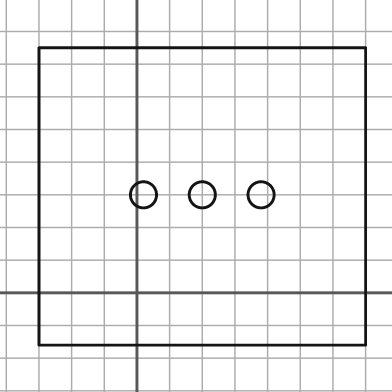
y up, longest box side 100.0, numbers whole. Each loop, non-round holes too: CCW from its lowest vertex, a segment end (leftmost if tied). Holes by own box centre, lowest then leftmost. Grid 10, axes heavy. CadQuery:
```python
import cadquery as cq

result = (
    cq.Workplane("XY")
    .moveTo(-30.0, -16.0)
    .lineTo(70.0, -16.0)
    .lineTo(70.0, 75.0)
    .lineTo(-30.0, 75.0)
    .close()
    .moveTo(2.0, 30.0)
    .circle(4.0)
    .moveTo(20.0, 30.0)
    .circle(4.0)
    .moveTo(38.0, 30.0)
    .circle(4.0)
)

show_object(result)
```